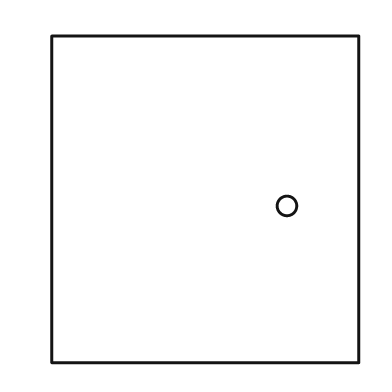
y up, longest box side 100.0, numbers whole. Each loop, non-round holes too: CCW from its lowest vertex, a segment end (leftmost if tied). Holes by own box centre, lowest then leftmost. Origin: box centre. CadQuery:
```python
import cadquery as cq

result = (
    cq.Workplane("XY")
    .moveTo(-47.0, -50.0)
    .lineTo(47.0, -50.0)
    .lineTo(47.0, 50.0)
    .lineTo(-47.0, 50.0)
    .close()
    .moveTo(25.0, -2.0)
    .circle(3.0)
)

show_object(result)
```